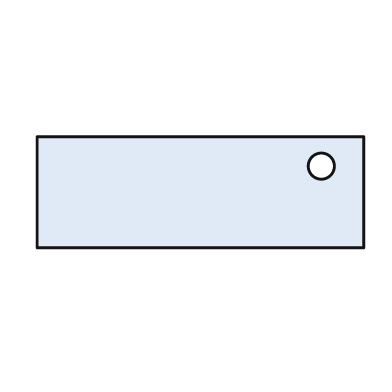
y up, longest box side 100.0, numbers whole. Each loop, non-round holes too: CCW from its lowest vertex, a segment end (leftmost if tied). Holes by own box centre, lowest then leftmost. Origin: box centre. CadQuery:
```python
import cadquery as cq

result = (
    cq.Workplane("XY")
    .moveTo(-50.0, -17.0)
    .lineTo(50.0, -17.0)
    .lineTo(50.0, 17.0)
    .lineTo(-50.0, 17.0)
    .close()
    .moveTo(37.0, 8.0)
    .circle(4.0)
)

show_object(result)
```